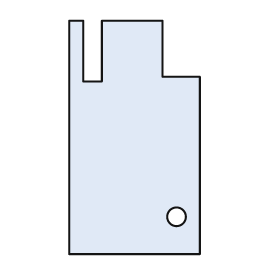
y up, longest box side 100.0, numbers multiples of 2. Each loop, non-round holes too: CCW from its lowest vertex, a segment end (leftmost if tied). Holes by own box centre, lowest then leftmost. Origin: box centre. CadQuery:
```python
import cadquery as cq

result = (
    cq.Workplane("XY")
    .moveTo(-28.0, -50.0)
    .lineTo(28.0, -50.0)
    .lineTo(28.0, 26.0)
    .lineTo(12.0, 26.0)
    .lineTo(12.0, 50.0)
    .lineTo(-14.0, 50.0)
    .lineTo(-14.0, 24.0)
    .lineTo(-22.0, 24.0)
    .lineTo(-22.0, 50.0)
    .lineTo(-28.0, 50.0)
    .close()
    .moveTo(18.0, -34.0)
    .circle(4.0)
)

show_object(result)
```